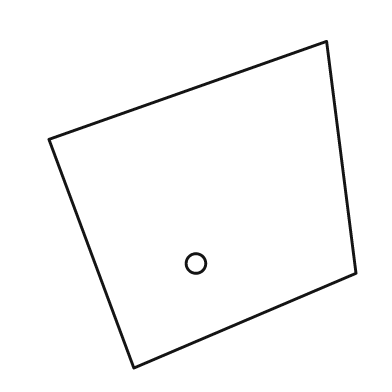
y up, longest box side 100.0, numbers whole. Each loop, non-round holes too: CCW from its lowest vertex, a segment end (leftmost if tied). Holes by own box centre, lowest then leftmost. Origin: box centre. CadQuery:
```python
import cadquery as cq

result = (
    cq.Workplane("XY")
    .moveTo(-21.0, -50.0)
    .lineTo(47.0, -21.0)
    .lineTo(38.0, 50.0)
    .lineTo(-47.0, 20.0)
    .close()
    .moveTo(-2.0, -18.0)
    .circle(3.0)
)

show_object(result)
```